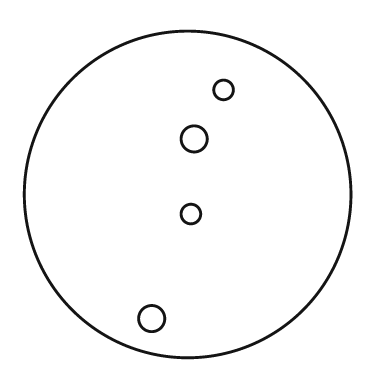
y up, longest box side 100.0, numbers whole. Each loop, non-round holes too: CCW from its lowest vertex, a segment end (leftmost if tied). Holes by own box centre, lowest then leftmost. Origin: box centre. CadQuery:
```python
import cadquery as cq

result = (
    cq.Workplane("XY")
    .moveTo(0.0, 0.0)
    .circle(50.0)
    .moveTo(-11.0, -38.0)
    .circle(4.0)
    .moveTo(1.0, -6.0)
    .circle(3.0)
    .moveTo(2.0, 17.0)
    .circle(4.0)
    .moveTo(11.0, 32.0)
    .circle(3.0)
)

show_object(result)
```